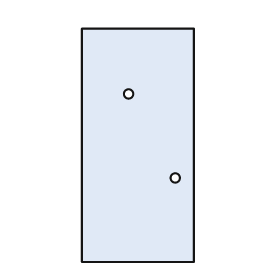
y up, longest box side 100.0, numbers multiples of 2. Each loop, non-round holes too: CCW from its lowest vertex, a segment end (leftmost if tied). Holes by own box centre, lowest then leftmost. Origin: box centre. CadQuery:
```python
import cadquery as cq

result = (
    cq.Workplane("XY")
    .moveTo(-24.0, -50.0)
    .lineTo(24.0, -50.0)
    .lineTo(24.0, 50.0)
    .lineTo(-24.0, 50.0)
    .close()
    .moveTo(16.0, -14.0)
    .circle(2.0)
    .moveTo(-4.0, 22.0)
    .circle(2.0)
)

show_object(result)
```